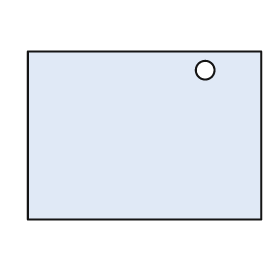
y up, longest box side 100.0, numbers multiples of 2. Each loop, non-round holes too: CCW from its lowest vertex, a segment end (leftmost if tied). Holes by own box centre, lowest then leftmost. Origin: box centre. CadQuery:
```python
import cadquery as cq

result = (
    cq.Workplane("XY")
    .moveTo(-50.0, -36.0)
    .lineTo(50.0, -36.0)
    .lineTo(50.0, 36.0)
    .lineTo(-50.0, 36.0)
    .close()
    .moveTo(26.0, 28.0)
    .circle(4.0)
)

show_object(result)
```